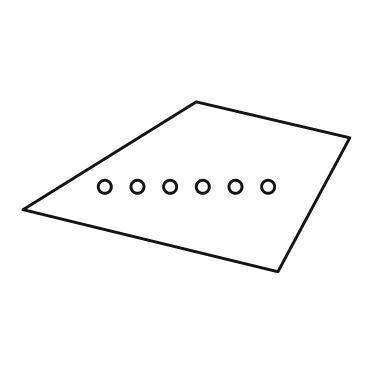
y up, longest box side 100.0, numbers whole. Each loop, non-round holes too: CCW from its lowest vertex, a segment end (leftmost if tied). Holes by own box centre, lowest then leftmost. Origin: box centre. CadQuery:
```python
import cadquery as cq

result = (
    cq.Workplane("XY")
    .moveTo(28.0, -26.0)
    .lineTo(50.0, 15.0)
    .lineTo(3.0, 26.0)
    .lineTo(-50.0, -7.0)
    .close()
    .moveTo(-25.0, 0.0)
    .circle(2.0)
    .moveTo(-15.0, 0.0)
    .circle(2.0)
    .moveTo(-5.0, 0.0)
    .circle(2.0)
    .moveTo(5.0, 0.0)
    .circle(2.0)
    .moveTo(15.0, 0.0)
    .circle(2.0)
    .moveTo(25.0, 0.0)
    .circle(2.0)
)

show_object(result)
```